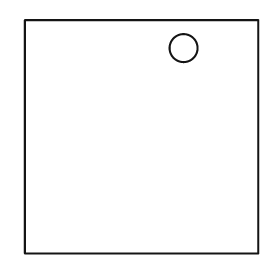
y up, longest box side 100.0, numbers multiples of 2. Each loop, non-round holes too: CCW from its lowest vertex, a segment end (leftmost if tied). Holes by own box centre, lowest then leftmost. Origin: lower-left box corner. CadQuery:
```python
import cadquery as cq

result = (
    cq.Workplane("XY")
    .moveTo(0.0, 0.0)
    .lineTo(100.0, 0.0)
    .lineTo(100.0, 100.0)
    .lineTo(0.0, 100.0)
    .close()
    .moveTo(68.0, 88.0)
    .circle(6.0)
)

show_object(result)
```